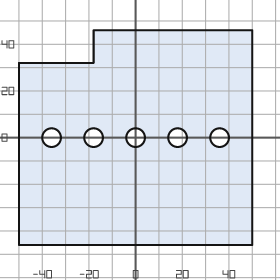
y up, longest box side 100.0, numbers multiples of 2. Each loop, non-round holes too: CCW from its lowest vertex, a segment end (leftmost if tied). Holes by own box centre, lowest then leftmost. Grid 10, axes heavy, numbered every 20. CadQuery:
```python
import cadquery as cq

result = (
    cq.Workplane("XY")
    .moveTo(-50.0, -46.0)
    .lineTo(50.0, -46.0)
    .lineTo(50.0, 46.0)
    .lineTo(-18.0, 46.0)
    .lineTo(-18.0, 32.0)
    .lineTo(-50.0, 32.0)
    .close()
    .moveTo(-36.0, 0.0)
    .circle(4.0)
    .moveTo(-18.0, 0.0)
    .circle(4.0)
    .moveTo(0.0, 0.0)
    .circle(4.0)
    .moveTo(18.0, 0.0)
    .circle(4.0)
    .moveTo(36.0, 0.0)
    .circle(4.0)
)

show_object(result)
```